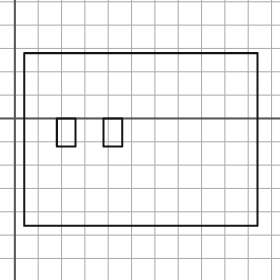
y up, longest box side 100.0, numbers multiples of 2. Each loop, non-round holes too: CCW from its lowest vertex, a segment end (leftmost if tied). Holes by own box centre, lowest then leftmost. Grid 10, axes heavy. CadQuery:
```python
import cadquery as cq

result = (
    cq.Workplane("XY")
    .moveTo(4.0, -46.0)
    .lineTo(104.0, -46.0)
    .lineTo(104.0, 28.0)
    .lineTo(4.0, 28.0)
    .close()
    .moveTo(18.0, -12.0)
    .lineTo(26.0, -12.0)
    .lineTo(26.0, 0.0)
    .lineTo(18.0, 0.0)
    .close()
    .moveTo(38.0, -12.0)
    .lineTo(46.0, -12.0)
    .lineTo(46.0, 0.0)
    .lineTo(38.0, 0.0)
    .close()
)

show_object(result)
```